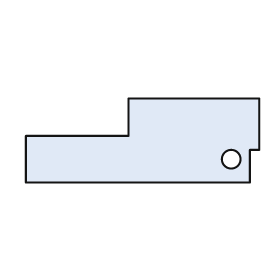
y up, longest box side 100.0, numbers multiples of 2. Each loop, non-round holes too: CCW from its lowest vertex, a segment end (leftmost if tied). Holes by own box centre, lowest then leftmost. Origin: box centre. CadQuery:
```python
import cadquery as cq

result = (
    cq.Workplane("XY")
    .moveTo(-50.0, -18.0)
    .lineTo(46.0, -18.0)
    .lineTo(46.0, -4.0)
    .lineTo(50.0, -4.0)
    .lineTo(50.0, 18.0)
    .lineTo(-6.0, 18.0)
    .lineTo(-6.0, 2.0)
    .lineTo(-50.0, 2.0)
    .close()
    .moveTo(38.0, -8.0)
    .circle(4.0)
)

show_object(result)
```